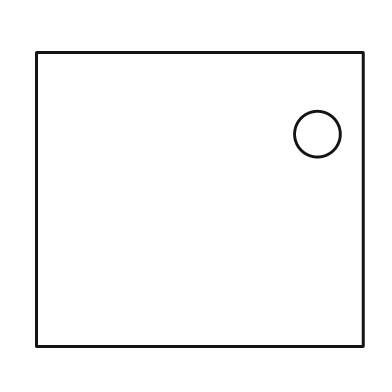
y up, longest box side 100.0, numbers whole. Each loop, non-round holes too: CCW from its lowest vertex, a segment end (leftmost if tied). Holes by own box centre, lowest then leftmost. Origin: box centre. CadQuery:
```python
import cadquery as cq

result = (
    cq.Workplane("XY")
    .moveTo(-50.0, -45.0)
    .lineTo(50.0, -45.0)
    .lineTo(50.0, 45.0)
    .lineTo(-50.0, 45.0)
    .close()
    .moveTo(36.0, 20.0)
    .circle(7.0)
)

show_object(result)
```